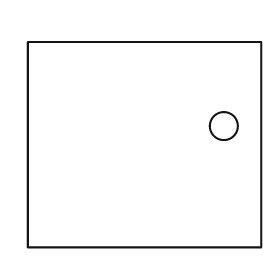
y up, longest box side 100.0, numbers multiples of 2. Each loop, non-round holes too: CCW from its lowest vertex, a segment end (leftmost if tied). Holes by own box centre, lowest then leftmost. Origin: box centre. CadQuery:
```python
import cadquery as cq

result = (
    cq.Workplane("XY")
    .moveTo(-50.0, -44.0)
    .lineTo(50.0, -44.0)
    .lineTo(50.0, 44.0)
    .lineTo(-50.0, 44.0)
    .close()
    .moveTo(34.0, 8.0)
    .circle(6.0)
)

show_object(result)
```